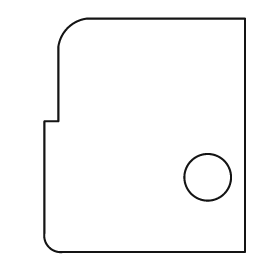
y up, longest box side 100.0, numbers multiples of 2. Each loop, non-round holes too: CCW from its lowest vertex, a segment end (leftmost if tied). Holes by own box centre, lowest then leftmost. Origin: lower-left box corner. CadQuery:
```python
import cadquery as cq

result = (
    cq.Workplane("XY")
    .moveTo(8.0, 0.0)
    .lineTo(86.0, 0.0)
    .lineTo(86.0, 100.0)
    .lineTo(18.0, 100.0)
    .threePointArc((10.0, 96.0), (6.0, 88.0))
    .lineTo(6.0, 56.0)
    .lineTo(0.0, 56.0)
    .lineTo(0.0, 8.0)
    .threePointArc((2.0, 2.0), (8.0, 0.0))
    .close()
    .moveTo(70.0, 32.0)
    .circle(10.0)
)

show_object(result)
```